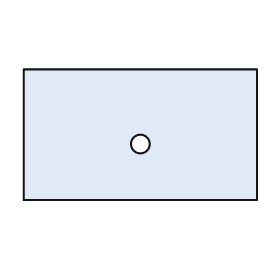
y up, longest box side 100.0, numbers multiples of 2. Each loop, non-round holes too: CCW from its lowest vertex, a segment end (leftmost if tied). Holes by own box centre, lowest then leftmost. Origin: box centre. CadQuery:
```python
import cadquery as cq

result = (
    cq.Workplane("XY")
    .moveTo(-50.0, -28.0)
    .lineTo(50.0, -28.0)
    .lineTo(50.0, 28.0)
    .lineTo(-50.0, 28.0)
    .close()
    .moveTo(0.0, -4.0)
    .circle(4.0)
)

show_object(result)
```